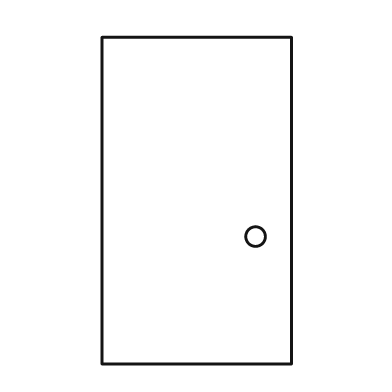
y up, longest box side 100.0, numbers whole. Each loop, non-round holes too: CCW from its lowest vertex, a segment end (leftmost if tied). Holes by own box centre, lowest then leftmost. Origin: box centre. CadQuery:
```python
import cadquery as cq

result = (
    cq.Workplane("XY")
    .moveTo(-29.0, -50.0)
    .lineTo(29.0, -50.0)
    .lineTo(29.0, 50.0)
    .lineTo(-29.0, 50.0)
    .close()
    .moveTo(18.0, -11.0)
    .circle(3.0)
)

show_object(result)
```